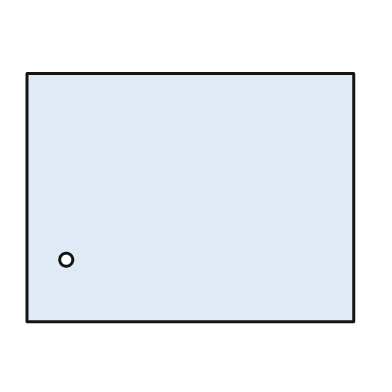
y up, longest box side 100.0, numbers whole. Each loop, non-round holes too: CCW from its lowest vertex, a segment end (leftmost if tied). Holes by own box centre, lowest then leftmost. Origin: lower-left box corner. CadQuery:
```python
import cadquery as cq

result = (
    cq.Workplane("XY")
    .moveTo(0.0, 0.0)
    .lineTo(100.0, 0.0)
    .lineTo(100.0, 76.0)
    .lineTo(0.0, 76.0)
    .close()
    .moveTo(12.0, 19.0)
    .circle(2.0)
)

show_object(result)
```